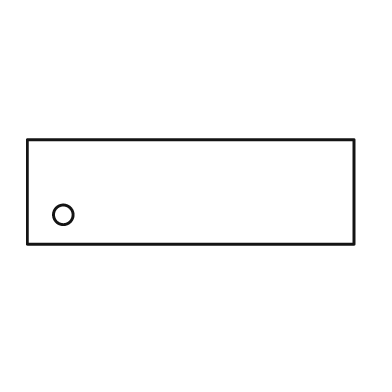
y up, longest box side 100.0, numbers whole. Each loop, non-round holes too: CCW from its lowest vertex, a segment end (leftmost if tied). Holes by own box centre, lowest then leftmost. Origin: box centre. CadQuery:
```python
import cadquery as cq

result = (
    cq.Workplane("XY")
    .moveTo(-50.0, -16.0)
    .lineTo(50.0, -16.0)
    .lineTo(50.0, 16.0)
    .lineTo(-50.0, 16.0)
    .close()
    .moveTo(-39.0, -7.0)
    .circle(3.0)
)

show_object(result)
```